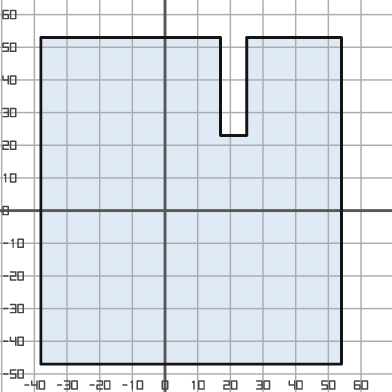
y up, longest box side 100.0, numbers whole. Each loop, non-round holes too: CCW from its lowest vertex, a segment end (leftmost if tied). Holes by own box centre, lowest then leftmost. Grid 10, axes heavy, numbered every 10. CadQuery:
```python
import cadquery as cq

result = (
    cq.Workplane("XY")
    .moveTo(-38.0, -47.0)
    .lineTo(54.0, -47.0)
    .lineTo(54.0, 53.0)
    .lineTo(25.0, 53.0)
    .lineTo(25.0, 23.0)
    .lineTo(17.0, 23.0)
    .lineTo(17.0, 53.0)
    .lineTo(-38.0, 53.0)
    .close()
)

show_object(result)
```